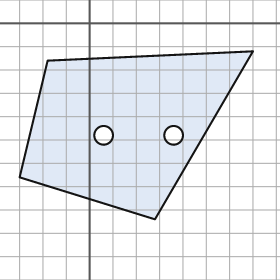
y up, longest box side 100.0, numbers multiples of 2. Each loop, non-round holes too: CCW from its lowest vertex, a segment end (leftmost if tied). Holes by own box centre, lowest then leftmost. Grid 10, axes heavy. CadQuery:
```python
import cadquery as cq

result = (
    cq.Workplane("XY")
    .moveTo(28.0, -84.0)
    .lineTo(70.0, -12.0)
    .lineTo(-18.0, -16.0)
    .lineTo(-30.0, -66.0)
    .close()
    .moveTo(6.0, -48.0)
    .circle(4.0)
    .moveTo(36.0, -48.0)
    .circle(4.0)
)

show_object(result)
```